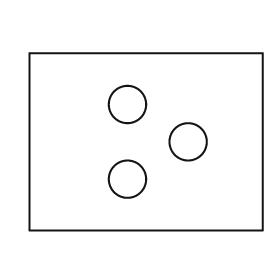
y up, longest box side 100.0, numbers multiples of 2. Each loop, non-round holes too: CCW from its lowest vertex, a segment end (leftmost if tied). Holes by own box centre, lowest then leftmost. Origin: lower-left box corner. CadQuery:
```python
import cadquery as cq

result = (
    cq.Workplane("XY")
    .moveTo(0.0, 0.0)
    .lineTo(100.0, 0.0)
    .lineTo(100.0, 76.0)
    .lineTo(0.0, 76.0)
    .close()
    .moveTo(42.0, 22.0)
    .circle(8.0)
    .moveTo(68.0, 38.0)
    .circle(8.0)
    .moveTo(42.0, 54.0)
    .circle(8.0)
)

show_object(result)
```